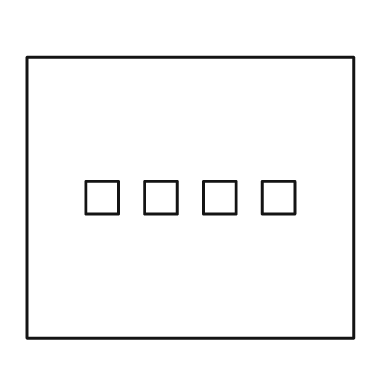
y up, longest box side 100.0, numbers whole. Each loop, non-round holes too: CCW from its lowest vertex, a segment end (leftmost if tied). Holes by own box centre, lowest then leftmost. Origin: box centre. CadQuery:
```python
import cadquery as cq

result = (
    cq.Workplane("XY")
    .moveTo(-50.0, -43.0)
    .lineTo(50.0, -43.0)
    .lineTo(50.0, 43.0)
    .lineTo(-50.0, 43.0)
    .close()
    .moveTo(-32.0, -5.0)
    .lineTo(-22.0, -5.0)
    .lineTo(-22.0, 5.0)
    .lineTo(-32.0, 5.0)
    .close()
    .moveTo(-14.0, -5.0)
    .lineTo(-4.0, -5.0)
    .lineTo(-4.0, 5.0)
    .lineTo(-14.0, 5.0)
    .close()
    .moveTo(4.0, -5.0)
    .lineTo(14.0, -5.0)
    .lineTo(14.0, 5.0)
    .lineTo(4.0, 5.0)
    .close()
    .moveTo(22.0, -5.0)
    .lineTo(32.0, -5.0)
    .lineTo(32.0, 5.0)
    .lineTo(22.0, 5.0)
    .close()
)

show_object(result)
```